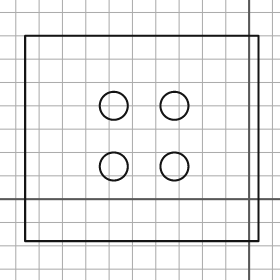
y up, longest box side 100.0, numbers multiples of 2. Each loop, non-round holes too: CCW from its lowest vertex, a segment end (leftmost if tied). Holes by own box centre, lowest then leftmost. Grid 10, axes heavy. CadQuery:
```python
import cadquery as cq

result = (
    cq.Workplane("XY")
    .moveTo(-96.0, -18.0)
    .lineTo(4.0, -18.0)
    .lineTo(4.0, 70.0)
    .lineTo(-96.0, 70.0)
    .close()
    .moveTo(-58.0, 14.0)
    .circle(6.0)
    .moveTo(-32.0, 14.0)
    .circle(6.0)
    .moveTo(-58.0, 40.0)
    .circle(6.0)
    .moveTo(-32.0, 40.0)
    .circle(6.0)
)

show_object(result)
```